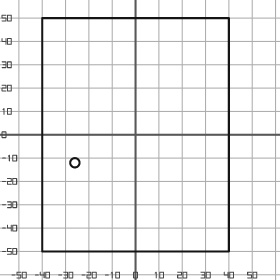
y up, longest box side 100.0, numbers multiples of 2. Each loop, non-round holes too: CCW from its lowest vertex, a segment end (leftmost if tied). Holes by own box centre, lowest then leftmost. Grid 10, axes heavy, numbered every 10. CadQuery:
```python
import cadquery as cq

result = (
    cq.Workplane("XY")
    .moveTo(-40.0, -50.0)
    .lineTo(40.0, -50.0)
    .lineTo(40.0, 50.0)
    .lineTo(-40.0, 50.0)
    .close()
    .moveTo(-26.0, -12.0)
    .circle(2.0)
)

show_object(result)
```